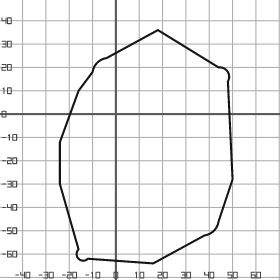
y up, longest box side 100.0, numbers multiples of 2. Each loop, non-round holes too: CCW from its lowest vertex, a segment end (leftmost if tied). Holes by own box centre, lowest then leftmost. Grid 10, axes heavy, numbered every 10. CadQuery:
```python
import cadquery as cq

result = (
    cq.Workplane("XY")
    .moveTo(16.0, -64.0)
    .lineTo(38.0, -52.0)
    .threePointArc((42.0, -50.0), (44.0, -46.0))
    .lineTo(50.0, -28.0)
    .lineTo(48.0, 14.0)
    .threePointArc((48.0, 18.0), (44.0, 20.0))
    .lineTo(18.0, 36.0)
    .lineTo(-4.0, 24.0)
    .threePointArc((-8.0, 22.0), (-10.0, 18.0))
    .lineTo(-16.0, 10.0)
    .lineTo(-24.0, -12.0)
    .lineTo(-24.0, -30.0)
    .lineTo(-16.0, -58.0)
    .threePointArc((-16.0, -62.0), (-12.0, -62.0))
    .close()
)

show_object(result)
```